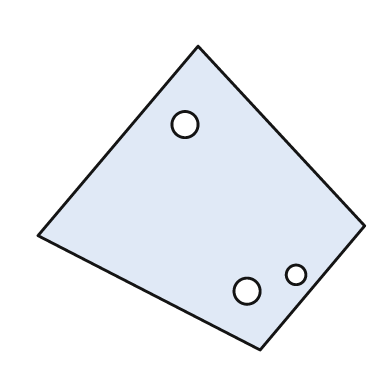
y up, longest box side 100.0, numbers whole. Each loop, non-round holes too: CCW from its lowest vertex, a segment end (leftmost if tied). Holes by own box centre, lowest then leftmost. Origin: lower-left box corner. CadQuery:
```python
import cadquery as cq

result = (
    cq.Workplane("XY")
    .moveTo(68.0, 0.0)
    .lineTo(100.0, 38.0)
    .lineTo(49.0, 93.0)
    .lineTo(0.0, 35.0)
    .close()
    .moveTo(64.0, 18.0)
    .circle(4.0)
    .moveTo(79.0, 23.0)
    .circle(3.0)
    .moveTo(45.0, 69.0)
    .circle(4.0)
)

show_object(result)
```